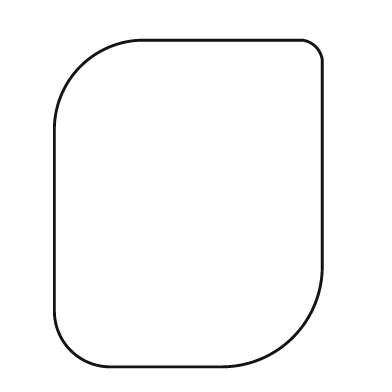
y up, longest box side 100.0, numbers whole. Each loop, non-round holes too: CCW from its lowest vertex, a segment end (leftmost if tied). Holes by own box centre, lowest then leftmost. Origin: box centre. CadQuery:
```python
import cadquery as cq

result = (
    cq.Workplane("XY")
    .moveTo(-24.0, -50.0)
    .lineTo(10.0, -50.0)
    .threePointArc((32.0, -41.0), (41.0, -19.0))
    .lineTo(41.0, 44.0)
    .threePointArc((39.0, 48.0), (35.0, 50.0))
    .lineTo(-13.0, 50.0)
    .threePointArc((-33.0, 42.0), (-41.0, 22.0))
    .lineTo(-41.0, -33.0)
    .threePointArc((-36.0, -45.0), (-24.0, -50.0))
    .close()
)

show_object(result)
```